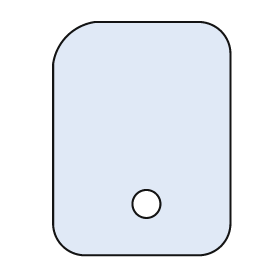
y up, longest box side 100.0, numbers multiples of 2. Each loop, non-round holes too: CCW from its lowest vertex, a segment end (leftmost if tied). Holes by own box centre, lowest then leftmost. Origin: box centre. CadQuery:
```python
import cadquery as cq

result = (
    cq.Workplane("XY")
    .moveTo(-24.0, -50.0)
    .lineTo(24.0, -50.0)
    .threePointArc((34.0, -46.0), (38.0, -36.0))
    .lineTo(38.0, 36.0)
    .threePointArc((34.0, 46.0), (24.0, 50.0))
    .lineTo(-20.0, 50.0)
    .threePointArc((-32.0, 44.0), (-38.0, 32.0))
    .lineTo(-38.0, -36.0)
    .threePointArc((-34.0, -46.0), (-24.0, -50.0))
    .close()
    .moveTo(2.0, -28.0)
    .circle(6.0)
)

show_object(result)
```